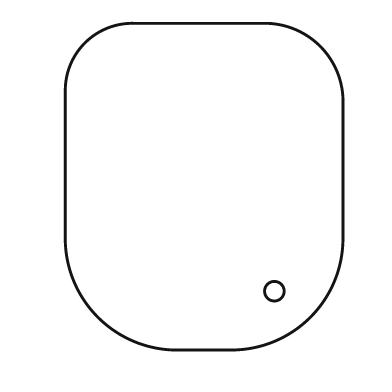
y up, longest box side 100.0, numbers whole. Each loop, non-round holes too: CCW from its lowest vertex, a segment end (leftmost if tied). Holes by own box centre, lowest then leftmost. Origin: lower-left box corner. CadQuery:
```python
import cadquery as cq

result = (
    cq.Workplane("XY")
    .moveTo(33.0, 0.0)
    .lineTo(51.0, 0.0)
    .threePointArc((75.0, 10.0), (85.0, 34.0))
    .lineTo(85.0, 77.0)
    .threePointArc((78.0, 93.0), (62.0, 100.0))
    .lineTo(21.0, 100.0)
    .threePointArc((6.0, 94.0), (0.0, 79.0))
    .lineTo(0.0, 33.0)
    .threePointArc((10.0, 10.0), (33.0, 0.0))
    .close()
    .moveTo(64.0, 18.0)
    .circle(3.0)
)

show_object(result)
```